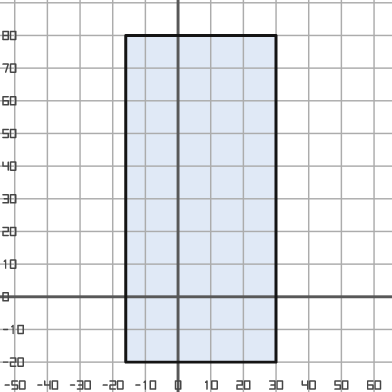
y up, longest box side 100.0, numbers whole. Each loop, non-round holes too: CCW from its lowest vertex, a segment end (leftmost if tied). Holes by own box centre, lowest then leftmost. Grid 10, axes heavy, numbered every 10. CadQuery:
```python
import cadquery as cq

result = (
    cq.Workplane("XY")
    .moveTo(-16.0, -20.0)
    .lineTo(30.0, -20.0)
    .lineTo(30.0, 80.0)
    .lineTo(-16.0, 80.0)
    .close()
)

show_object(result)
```